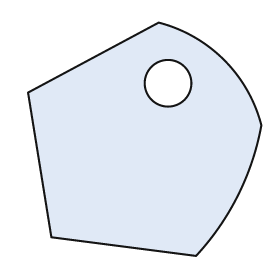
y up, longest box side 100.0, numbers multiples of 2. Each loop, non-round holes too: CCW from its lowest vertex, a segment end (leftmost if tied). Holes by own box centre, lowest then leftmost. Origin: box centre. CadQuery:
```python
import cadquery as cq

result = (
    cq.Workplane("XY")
    .moveTo(22.0, -50.0)
    .threePointArc((40.0, -24.0), (50.0, 6.0))
    .threePointArc((34.0, 34.0), (6.0, 50.0))
    .lineTo(-50.0, 20.0)
    .lineTo(-40.0, -42.0)
    .close()
    .moveTo(10.0, 24.0)
    .circle(10.0)
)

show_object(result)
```